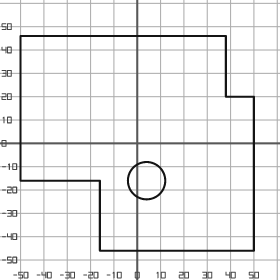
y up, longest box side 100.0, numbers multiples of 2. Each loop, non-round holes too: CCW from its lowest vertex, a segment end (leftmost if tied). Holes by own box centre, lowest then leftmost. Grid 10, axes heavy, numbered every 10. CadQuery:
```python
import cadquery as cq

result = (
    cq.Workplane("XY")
    .moveTo(-16.0, -46.0)
    .lineTo(50.0, -46.0)
    .lineTo(50.0, 20.0)
    .lineTo(38.0, 20.0)
    .lineTo(38.0, 46.0)
    .lineTo(-50.0, 46.0)
    .lineTo(-50.0, -16.0)
    .lineTo(-16.0, -16.0)
    .close()
    .moveTo(4.0, -16.0)
    .circle(8.0)
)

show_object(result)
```